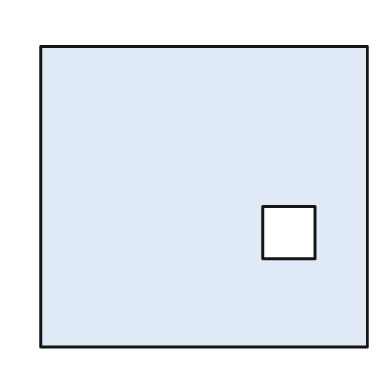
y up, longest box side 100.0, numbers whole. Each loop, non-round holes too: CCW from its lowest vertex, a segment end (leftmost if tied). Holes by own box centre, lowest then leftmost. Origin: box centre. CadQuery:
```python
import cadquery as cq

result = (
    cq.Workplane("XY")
    .moveTo(-50.0, -46.0)
    .lineTo(50.0, -46.0)
    .lineTo(50.0, 46.0)
    .lineTo(-50.0, 46.0)
    .close()
    .moveTo(18.0, -19.0)
    .lineTo(34.0, -19.0)
    .lineTo(34.0, -3.0)
    .lineTo(18.0, -3.0)
    .close()
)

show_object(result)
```